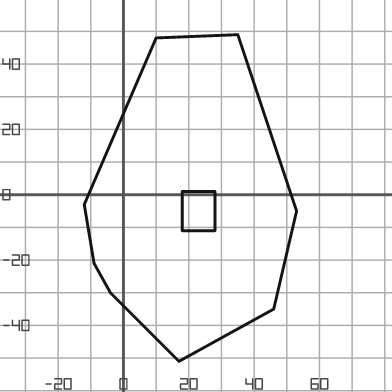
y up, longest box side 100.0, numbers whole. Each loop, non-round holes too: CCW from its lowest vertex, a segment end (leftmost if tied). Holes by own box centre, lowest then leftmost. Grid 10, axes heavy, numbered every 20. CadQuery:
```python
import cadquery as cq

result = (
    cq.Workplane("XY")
    .moveTo(17.0, -51.0)
    .lineTo(46.0, -35.0)
    .lineTo(53.0, -5.0)
    .lineTo(35.0, 49.0)
    .lineTo(10.0, 48.0)
    .lineTo(-12.0, -3.0)
    .lineTo(-9.0, -21.0)
    .lineTo(-4.0, -30.0)
    .close()
    .moveTo(18.0, -11.0)
    .lineTo(28.0, -11.0)
    .lineTo(28.0, 1.0)
    .lineTo(18.0, 1.0)
    .close()
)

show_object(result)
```